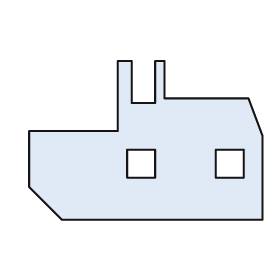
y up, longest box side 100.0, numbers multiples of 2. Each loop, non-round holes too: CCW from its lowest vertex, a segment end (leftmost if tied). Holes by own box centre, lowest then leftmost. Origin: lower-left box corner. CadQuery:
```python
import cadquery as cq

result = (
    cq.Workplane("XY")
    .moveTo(14.0, 0.0)
    .lineTo(100.0, 0.0)
    .lineTo(100.0, 36.0)
    .lineTo(94.0, 52.0)
    .lineTo(58.0, 52.0)
    .lineTo(58.0, 68.0)
    .lineTo(54.0, 68.0)
    .lineTo(54.0, 50.0)
    .lineTo(44.0, 50.0)
    .lineTo(44.0, 68.0)
    .lineTo(38.0, 68.0)
    .lineTo(38.0, 38.0)
    .lineTo(0.0, 38.0)
    .lineTo(0.0, 14.0)
    .close()
    .moveTo(42.0, 18.0)
    .lineTo(54.0, 18.0)
    .lineTo(54.0, 30.0)
    .lineTo(42.0, 30.0)
    .close()
    .moveTo(80.0, 18.0)
    .lineTo(92.0, 18.0)
    .lineTo(92.0, 30.0)
    .lineTo(80.0, 30.0)
    .close()
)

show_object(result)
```